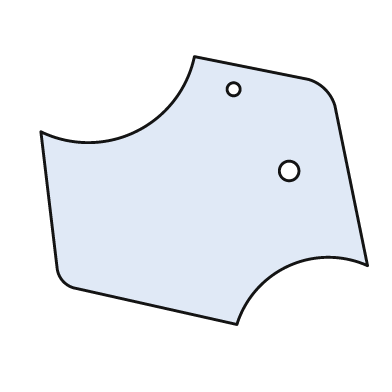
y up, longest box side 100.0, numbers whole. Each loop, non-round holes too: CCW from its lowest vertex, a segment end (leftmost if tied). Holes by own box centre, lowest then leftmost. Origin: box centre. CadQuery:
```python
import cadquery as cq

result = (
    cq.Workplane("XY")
    .moveTo(10.0, -41.0)
    .threePointArc((26.0, -23.0), (50.0, -23.0))
    .lineTo(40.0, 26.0)
    .threePointArc((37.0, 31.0), (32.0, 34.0))
    .lineTo(-3.0, 41.0)
    .threePointArc((-21.0, 18.0), (-50.0, 18.0))
    .lineTo(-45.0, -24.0)
    .threePointArc((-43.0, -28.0), (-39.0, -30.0))
    .close()
    .moveTo(26.0, 6.0)
    .circle(3.0)
    .moveTo(9.0, 31.0)
    .circle(2.0)
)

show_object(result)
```